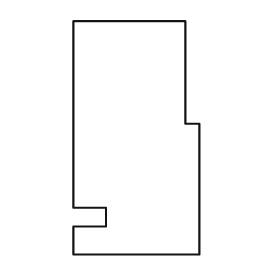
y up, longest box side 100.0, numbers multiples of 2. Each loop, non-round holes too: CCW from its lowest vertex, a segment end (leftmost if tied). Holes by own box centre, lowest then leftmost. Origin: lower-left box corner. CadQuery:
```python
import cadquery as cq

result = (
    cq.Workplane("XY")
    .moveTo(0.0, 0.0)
    .lineTo(54.0, 0.0)
    .lineTo(54.0, 56.0)
    .lineTo(48.0, 56.0)
    .lineTo(48.0, 100.0)
    .lineTo(0.0, 100.0)
    .lineTo(0.0, 20.0)
    .lineTo(14.0, 20.0)
    .lineTo(14.0, 12.0)
    .lineTo(0.0, 12.0)
    .close()
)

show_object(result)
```